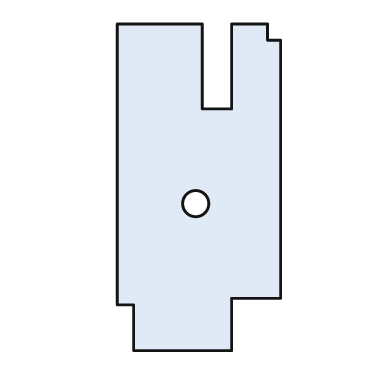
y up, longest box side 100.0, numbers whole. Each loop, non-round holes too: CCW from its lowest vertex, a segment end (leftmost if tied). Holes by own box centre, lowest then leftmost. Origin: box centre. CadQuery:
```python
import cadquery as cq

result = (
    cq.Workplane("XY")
    .moveTo(-20.0, -50.0)
    .lineTo(10.0, -50.0)
    .lineTo(10.0, -34.0)
    .lineTo(25.0, -34.0)
    .lineTo(25.0, 45.0)
    .lineTo(21.0, 45.0)
    .lineTo(21.0, 50.0)
    .lineTo(10.0, 50.0)
    .lineTo(10.0, 24.0)
    .lineTo(1.0, 24.0)
    .lineTo(1.0, 50.0)
    .lineTo(-25.0, 50.0)
    .lineTo(-25.0, -36.0)
    .lineTo(-20.0, -36.0)
    .close()
    .moveTo(-1.0, -5.0)
    .circle(4.0)
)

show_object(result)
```